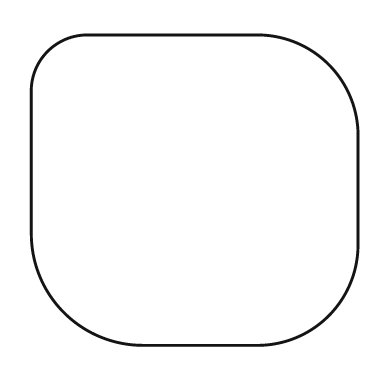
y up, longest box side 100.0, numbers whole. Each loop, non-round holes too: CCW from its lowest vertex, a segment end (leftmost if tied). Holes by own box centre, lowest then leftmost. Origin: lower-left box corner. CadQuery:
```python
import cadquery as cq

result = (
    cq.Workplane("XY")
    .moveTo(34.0, 0.0)
    .lineTo(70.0, 0.0)
    .threePointArc((91.0, 9.0), (100.0, 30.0))
    .lineTo(100.0, 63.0)
    .threePointArc((91.0, 86.0), (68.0, 95.0))
    .lineTo(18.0, 95.0)
    .threePointArc((5.0, 90.0), (0.0, 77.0))
    .lineTo(0.0, 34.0)
    .threePointArc((10.0, 10.0), (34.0, 0.0))
    .close()
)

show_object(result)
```